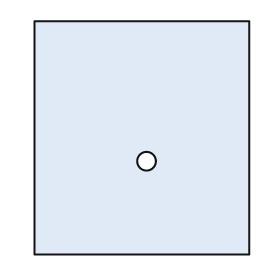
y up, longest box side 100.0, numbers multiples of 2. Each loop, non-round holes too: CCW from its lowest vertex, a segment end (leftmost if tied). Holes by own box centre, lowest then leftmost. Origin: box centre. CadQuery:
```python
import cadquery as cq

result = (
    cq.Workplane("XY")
    .moveTo(-46.0, -50.0)
    .lineTo(46.0, -50.0)
    .lineTo(46.0, 50.0)
    .lineTo(-46.0, 50.0)
    .close()
    .moveTo(2.0, -10.0)
    .circle(4.0)
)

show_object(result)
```